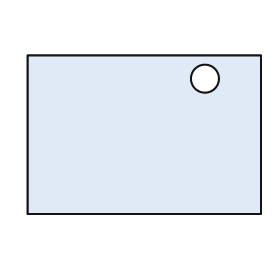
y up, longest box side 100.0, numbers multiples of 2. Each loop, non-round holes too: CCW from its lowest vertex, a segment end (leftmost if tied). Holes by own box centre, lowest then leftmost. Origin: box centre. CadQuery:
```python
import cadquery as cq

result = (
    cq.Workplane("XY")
    .moveTo(-50.0, -34.0)
    .lineTo(50.0, -34.0)
    .lineTo(50.0, 34.0)
    .lineTo(-50.0, 34.0)
    .close()
    .moveTo(26.0, 24.0)
    .circle(6.0)
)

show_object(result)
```